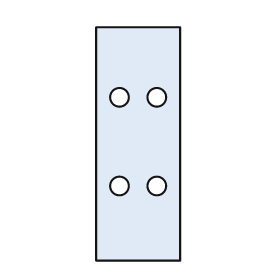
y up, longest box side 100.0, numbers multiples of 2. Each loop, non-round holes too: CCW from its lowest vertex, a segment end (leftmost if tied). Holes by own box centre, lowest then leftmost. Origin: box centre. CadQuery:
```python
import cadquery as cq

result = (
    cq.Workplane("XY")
    .moveTo(-18.0, -50.0)
    .lineTo(18.0, -50.0)
    .lineTo(18.0, 50.0)
    .lineTo(-18.0, 50.0)
    .close()
    .moveTo(-8.0, -18.0)
    .circle(4.0)
    .moveTo(8.0, -18.0)
    .circle(4.0)
    .moveTo(-8.0, 20.0)
    .circle(4.0)
    .moveTo(8.0, 20.0)
    .circle(4.0)
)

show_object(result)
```